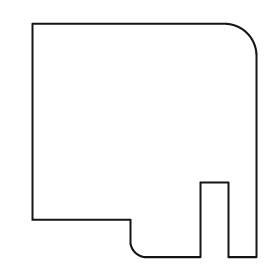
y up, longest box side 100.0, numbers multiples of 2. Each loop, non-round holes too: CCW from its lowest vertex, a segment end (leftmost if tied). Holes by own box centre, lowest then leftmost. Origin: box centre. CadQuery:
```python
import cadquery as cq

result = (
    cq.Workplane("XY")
    .moveTo(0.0, -50.0)
    .lineTo(24.0, -50.0)
    .lineTo(24.0, -18.0)
    .lineTo(36.0, -18.0)
    .lineTo(36.0, -50.0)
    .lineTo(48.0, -50.0)
    .lineTo(48.0, 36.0)
    .threePointArc((44.0, 46.0), (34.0, 50.0))
    .lineTo(-48.0, 50.0)
    .lineTo(-48.0, -34.0)
    .lineTo(-6.0, -34.0)
    .lineTo(-6.0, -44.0)
    .threePointArc((-4.0, -48.0), (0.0, -50.0))
    .close()
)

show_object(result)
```